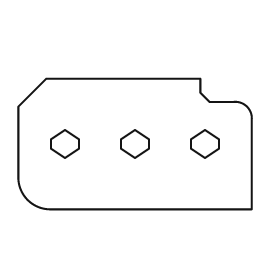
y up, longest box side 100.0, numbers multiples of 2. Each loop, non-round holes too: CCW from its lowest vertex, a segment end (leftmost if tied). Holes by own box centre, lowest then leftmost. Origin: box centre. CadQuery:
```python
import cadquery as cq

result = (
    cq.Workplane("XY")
    .moveTo(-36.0, -28.0)
    .lineTo(50.0, -28.0)
    .lineTo(50.0, 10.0)
    .threePointArc((48.0, 16.0), (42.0, 18.0))
    .lineTo(32.0, 18.0)
    .lineTo(28.0, 22.0)
    .lineTo(28.0, 28.0)
    .lineTo(-38.0, 28.0)
    .lineTo(-50.0, 16.0)
    .lineTo(-50.0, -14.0)
    .threePointArc((-46.0, -24.0), (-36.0, -28.0))
    .close()
    .moveTo(-30.0, -6.0)
    .lineTo(-24.0, -2.0)
    .lineTo(-24.0, 2.0)
    .lineTo(-30.0, 6.0)
    .lineTo(-36.0, 2.0)
    .lineTo(-36.0, -2.0)
    .close()
    .moveTo(0.0, -6.0)
    .lineTo(6.0, -2.0)
    .lineTo(6.0, 2.0)
    .lineTo(0.0, 6.0)
    .lineTo(-6.0, 2.0)
    .lineTo(-6.0, -2.0)
    .close()
    .moveTo(30.0, -6.0)
    .lineTo(36.0, -2.0)
    .lineTo(36.0, 2.0)
    .lineTo(30.0, 6.0)
    .lineTo(24.0, 2.0)
    .lineTo(24.0, -2.0)
    .close()
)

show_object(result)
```